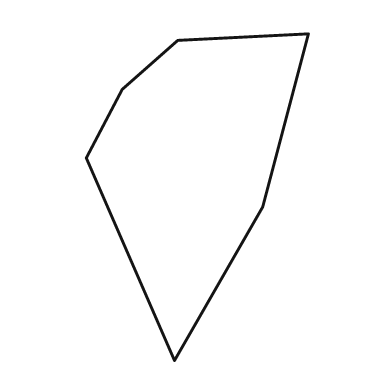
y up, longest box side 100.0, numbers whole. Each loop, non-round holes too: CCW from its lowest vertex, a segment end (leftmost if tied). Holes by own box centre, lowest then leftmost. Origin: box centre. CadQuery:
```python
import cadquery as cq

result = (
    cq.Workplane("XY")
    .moveTo(-7.0, -50.0)
    .lineTo(20.0, -3.0)
    .lineTo(34.0, 50.0)
    .lineTo(-6.0, 48.0)
    .lineTo(-23.0, 33.0)
    .lineTo(-34.0, 12.0)
    .close()
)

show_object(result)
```